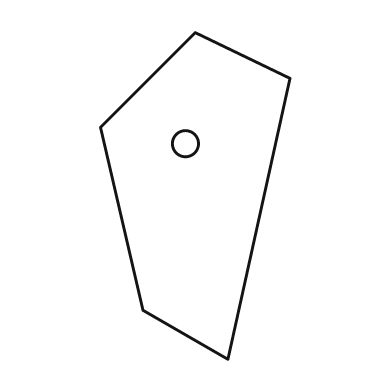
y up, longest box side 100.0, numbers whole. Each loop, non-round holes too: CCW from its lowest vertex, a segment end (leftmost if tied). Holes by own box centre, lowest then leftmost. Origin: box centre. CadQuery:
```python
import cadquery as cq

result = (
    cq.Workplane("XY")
    .moveTo(10.0, -50.0)
    .lineTo(29.0, 36.0)
    .lineTo(0.0, 50.0)
    .lineTo(-29.0, 21.0)
    .lineTo(-16.0, -35.0)
    .close()
    .moveTo(-3.0, 16.0)
    .circle(4.0)
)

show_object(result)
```